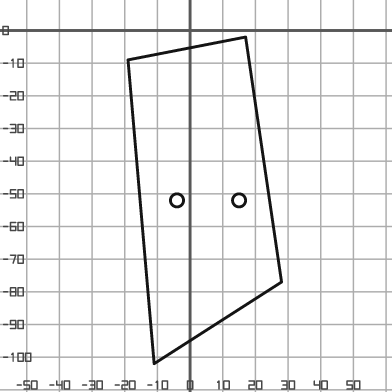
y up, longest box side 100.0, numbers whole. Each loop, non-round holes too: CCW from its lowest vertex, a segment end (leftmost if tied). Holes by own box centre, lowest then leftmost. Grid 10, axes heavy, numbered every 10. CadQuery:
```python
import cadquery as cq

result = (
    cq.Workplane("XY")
    .moveTo(-11.0, -102.0)
    .lineTo(28.0, -77.0)
    .lineTo(17.0, -2.0)
    .lineTo(-19.0, -9.0)
    .close()
    .moveTo(-4.0, -52.0)
    .circle(2.0)
    .moveTo(15.0, -52.0)
    .circle(2.0)
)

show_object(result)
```